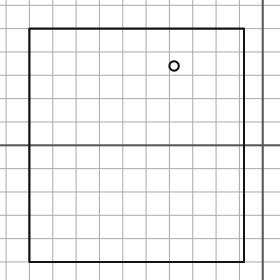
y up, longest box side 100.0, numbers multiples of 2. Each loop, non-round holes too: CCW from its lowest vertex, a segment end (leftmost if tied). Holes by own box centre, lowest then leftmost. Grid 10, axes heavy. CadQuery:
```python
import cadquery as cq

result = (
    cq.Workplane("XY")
    .moveTo(-100.0, -50.0)
    .lineTo(-8.0, -50.0)
    .lineTo(-8.0, 50.0)
    .lineTo(-100.0, 50.0)
    .close()
    .moveTo(-38.0, 34.0)
    .circle(2.0)
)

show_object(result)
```